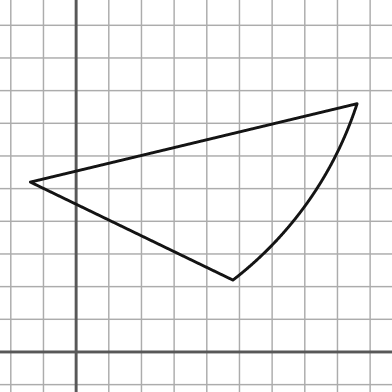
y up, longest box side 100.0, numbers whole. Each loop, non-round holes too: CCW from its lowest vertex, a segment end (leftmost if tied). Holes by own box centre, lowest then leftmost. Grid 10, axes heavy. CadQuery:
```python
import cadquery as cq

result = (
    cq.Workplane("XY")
    .moveTo(48.0, 22.0)
    .threePointArc((71.0, 46.0), (86.0, 76.0))
    .lineTo(-14.0, 52.0)
    .close()
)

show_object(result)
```